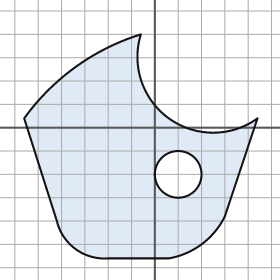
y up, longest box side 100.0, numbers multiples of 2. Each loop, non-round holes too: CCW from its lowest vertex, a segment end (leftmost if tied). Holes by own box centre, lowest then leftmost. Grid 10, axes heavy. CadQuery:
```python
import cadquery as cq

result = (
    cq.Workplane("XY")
    .moveTo(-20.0, -56.0)
    .lineTo(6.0, -56.0)
    .threePointArc((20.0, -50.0), (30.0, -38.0))
    .lineTo(44.0, 4.0)
    .threePointArc((6.0, 4.0), (-6.0, 40.0))
    .threePointArc((-34.0, 26.0), (-56.0, 4.0))
    .lineTo(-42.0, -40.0)
    .threePointArc((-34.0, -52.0), (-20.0, -56.0))
    .close()
    .moveTo(10.0, -20.0)
    .circle(10.0)
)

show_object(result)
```